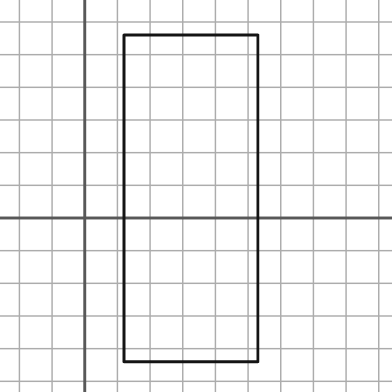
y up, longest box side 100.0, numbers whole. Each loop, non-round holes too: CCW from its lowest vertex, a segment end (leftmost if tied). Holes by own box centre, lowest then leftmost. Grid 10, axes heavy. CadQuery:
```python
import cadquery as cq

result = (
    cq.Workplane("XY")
    .moveTo(12.0, -44.0)
    .lineTo(53.0, -44.0)
    .lineTo(53.0, 56.0)
    .lineTo(12.0, 56.0)
    .close()
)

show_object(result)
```